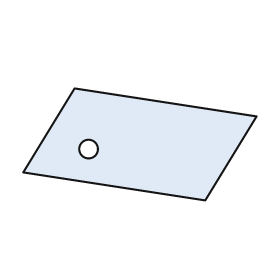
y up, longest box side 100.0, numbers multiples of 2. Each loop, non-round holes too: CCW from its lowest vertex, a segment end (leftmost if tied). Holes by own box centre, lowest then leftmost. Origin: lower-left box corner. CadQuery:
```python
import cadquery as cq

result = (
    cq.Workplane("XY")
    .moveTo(78.0, 0.0)
    .lineTo(100.0, 36.0)
    .lineTo(22.0, 48.0)
    .lineTo(0.0, 12.0)
    .close()
    .moveTo(28.0, 22.0)
    .circle(4.0)
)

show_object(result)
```